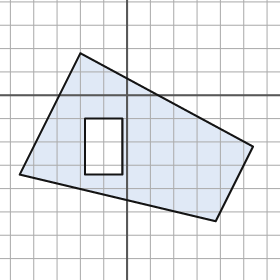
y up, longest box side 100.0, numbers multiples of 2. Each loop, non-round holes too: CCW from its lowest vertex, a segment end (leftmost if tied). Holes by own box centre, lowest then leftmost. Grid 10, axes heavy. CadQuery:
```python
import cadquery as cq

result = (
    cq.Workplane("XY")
    .moveTo(38.0, -54.0)
    .lineTo(54.0, -22.0)
    .lineTo(-20.0, 18.0)
    .lineTo(-46.0, -34.0)
    .close()
    .moveTo(-18.0, -34.0)
    .lineTo(-2.0, -34.0)
    .lineTo(-2.0, -10.0)
    .lineTo(-18.0, -10.0)
    .close()
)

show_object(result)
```